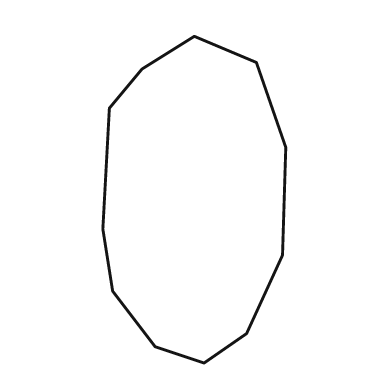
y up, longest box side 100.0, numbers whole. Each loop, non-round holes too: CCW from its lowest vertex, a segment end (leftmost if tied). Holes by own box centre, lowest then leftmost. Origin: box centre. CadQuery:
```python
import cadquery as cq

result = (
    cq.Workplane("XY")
    .moveTo(3.0, -50.0)
    .lineTo(16.0, -41.0)
    .lineTo(27.0, -17.0)
    .lineTo(28.0, 16.0)
    .lineTo(19.0, 42.0)
    .lineTo(0.0, 50.0)
    .lineTo(-16.0, 40.0)
    .lineTo(-26.0, 28.0)
    .lineTo(-28.0, -9.0)
    .lineTo(-25.0, -28.0)
    .lineTo(-12.0, -45.0)
    .close()
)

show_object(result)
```